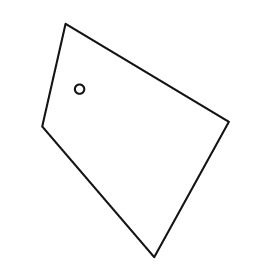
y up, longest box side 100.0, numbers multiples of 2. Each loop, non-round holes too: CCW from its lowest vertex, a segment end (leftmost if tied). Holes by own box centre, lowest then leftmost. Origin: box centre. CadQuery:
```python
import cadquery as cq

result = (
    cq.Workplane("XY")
    .moveTo(8.0, -50.0)
    .lineTo(40.0, 8.0)
    .lineTo(-30.0, 50.0)
    .lineTo(-40.0, 6.0)
    .close()
    .moveTo(-24.0, 22.0)
    .circle(2.0)
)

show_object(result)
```